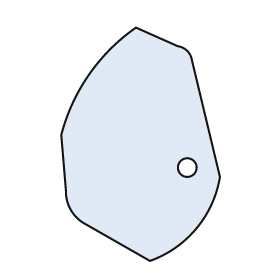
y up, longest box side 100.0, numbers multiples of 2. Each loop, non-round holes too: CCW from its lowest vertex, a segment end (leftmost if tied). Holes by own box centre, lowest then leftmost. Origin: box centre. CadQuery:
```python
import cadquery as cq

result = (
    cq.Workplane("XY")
    .moveTo(4.0, -50.0)
    .threePointArc((24.0, -36.0), (34.0, -14.0))
    .lineTo(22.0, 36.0)
    .threePointArc((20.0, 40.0), (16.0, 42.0))
    .lineTo(-2.0, 50.0)
    .threePointArc((-22.0, 30.0), (-34.0, 4.0))
    .lineTo(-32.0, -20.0)
    .threePointArc((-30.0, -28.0), (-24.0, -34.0))
    .close()
    .moveTo(20.0, -10.0)
    .circle(4.0)
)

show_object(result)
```